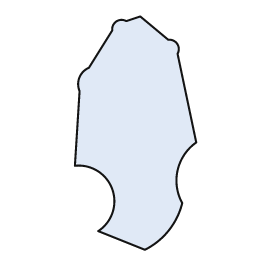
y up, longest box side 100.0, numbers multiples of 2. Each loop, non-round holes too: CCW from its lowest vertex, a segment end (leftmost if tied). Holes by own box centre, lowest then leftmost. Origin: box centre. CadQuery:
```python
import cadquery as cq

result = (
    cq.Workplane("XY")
    .moveTo(4.0, -50.0)
    .threePointArc((14.0, -42.0), (20.0, -30.0))
    .threePointArc((18.0, -16.0), (26.0, -4.0))
    .lineTo(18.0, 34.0)
    .threePointArc((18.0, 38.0), (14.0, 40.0))
    .lineTo(2.0, 50.0)
    .lineTo(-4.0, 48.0)
    .threePointArc((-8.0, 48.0), (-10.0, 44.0))
    .lineTo(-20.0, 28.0)
    .threePointArc((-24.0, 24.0), (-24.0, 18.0))
    .lineTo(-26.0, -14.0)
    .threePointArc((-10.0, -24.0), (-16.0, -42.0))
    .close()
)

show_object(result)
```